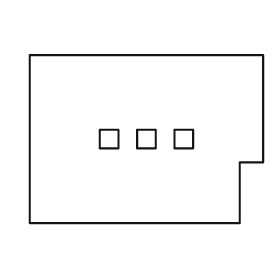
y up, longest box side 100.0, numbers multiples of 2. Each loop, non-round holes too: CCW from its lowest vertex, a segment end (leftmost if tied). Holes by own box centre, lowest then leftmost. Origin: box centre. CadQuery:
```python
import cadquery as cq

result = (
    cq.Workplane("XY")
    .moveTo(-50.0, -36.0)
    .lineTo(40.0, -36.0)
    .lineTo(40.0, -10.0)
    .lineTo(50.0, -10.0)
    .lineTo(50.0, 36.0)
    .lineTo(-50.0, 36.0)
    .close()
    .moveTo(-20.0, -4.0)
    .lineTo(-12.0, -4.0)
    .lineTo(-12.0, 4.0)
    .lineTo(-20.0, 4.0)
    .close()
    .moveTo(-4.0, -4.0)
    .lineTo(4.0, -4.0)
    .lineTo(4.0, 4.0)
    .lineTo(-4.0, 4.0)
    .close()
    .moveTo(12.0, -4.0)
    .lineTo(20.0, -4.0)
    .lineTo(20.0, 4.0)
    .lineTo(12.0, 4.0)
    .close()
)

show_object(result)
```